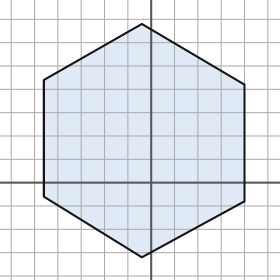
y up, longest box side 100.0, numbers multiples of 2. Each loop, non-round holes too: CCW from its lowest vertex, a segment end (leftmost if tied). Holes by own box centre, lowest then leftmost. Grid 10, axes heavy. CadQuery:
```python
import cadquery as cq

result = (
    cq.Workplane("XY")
    .moveTo(-4.0, -32.0)
    .lineTo(40.0, -8.0)
    .lineTo(40.0, 42.0)
    .lineTo(-4.0, 68.0)
    .lineTo(-46.0, 44.0)
    .lineTo(-46.0, -6.0)
    .close()
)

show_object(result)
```